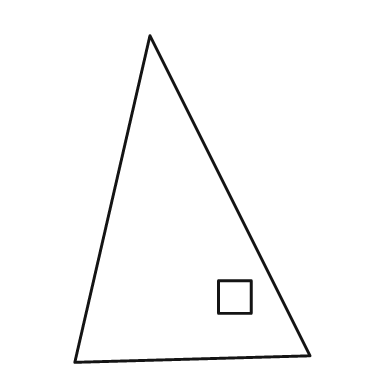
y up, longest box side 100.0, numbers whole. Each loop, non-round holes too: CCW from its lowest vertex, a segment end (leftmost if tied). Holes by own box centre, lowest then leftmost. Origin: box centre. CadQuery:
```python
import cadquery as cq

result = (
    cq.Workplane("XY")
    .moveTo(-36.0, -50.0)
    .lineTo(36.0, -48.0)
    .lineTo(-13.0, 50.0)
    .close()
    .moveTo(8.0, -35.0)
    .lineTo(18.0, -35.0)
    .lineTo(18.0, -25.0)
    .lineTo(8.0, -25.0)
    .close()
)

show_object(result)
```